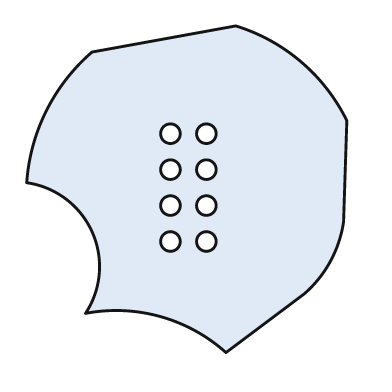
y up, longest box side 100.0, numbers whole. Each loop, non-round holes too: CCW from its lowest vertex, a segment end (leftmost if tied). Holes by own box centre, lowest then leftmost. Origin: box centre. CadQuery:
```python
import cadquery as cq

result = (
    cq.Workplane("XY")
    .moveTo(12.0, -50.0)
    .lineTo(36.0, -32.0)
    .threePointArc((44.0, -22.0), (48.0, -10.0))
    .lineTo(49.0, 21.0)
    .threePointArc((35.0, 39.0), (15.0, 50.0))
    .lineTo(-29.0, 42.0)
    .threePointArc((-43.0, 24.0), (-49.0, 2.0))
    .threePointArc((-29.0, -13.0), (-31.0, -38.0))
    .threePointArc((-8.0, -39.0), (12.0, -50.0))
    .close()
    .moveTo(-5.0, -16.0)
    .circle(3.0)
    .moveTo(6.0, -16.0)
    .circle(3.0)
    .moveTo(-5.0, -5.0)
    .circle(3.0)
    .moveTo(6.0, -5.0)
    .circle(3.0)
    .moveTo(-5.0, 6.0)
    .circle(3.0)
    .moveTo(6.0, 6.0)
    .circle(3.0)
    .moveTo(-5.0, 17.0)
    .circle(3.0)
    .moveTo(6.0, 17.0)
    .circle(3.0)
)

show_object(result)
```